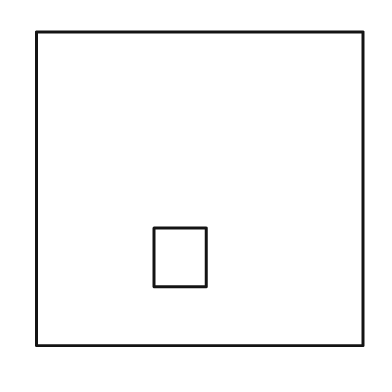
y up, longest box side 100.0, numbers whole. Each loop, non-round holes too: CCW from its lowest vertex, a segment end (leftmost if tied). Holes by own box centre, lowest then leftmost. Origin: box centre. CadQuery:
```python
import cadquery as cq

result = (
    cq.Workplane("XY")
    .moveTo(-50.0, -48.0)
    .lineTo(50.0, -48.0)
    .lineTo(50.0, 48.0)
    .lineTo(-50.0, 48.0)
    .close()
    .moveTo(-14.0, -30.0)
    .lineTo(2.0, -30.0)
    .lineTo(2.0, -12.0)
    .lineTo(-14.0, -12.0)
    .close()
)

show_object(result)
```